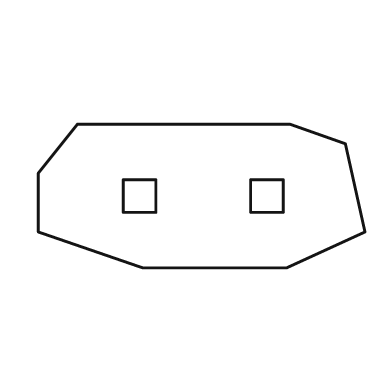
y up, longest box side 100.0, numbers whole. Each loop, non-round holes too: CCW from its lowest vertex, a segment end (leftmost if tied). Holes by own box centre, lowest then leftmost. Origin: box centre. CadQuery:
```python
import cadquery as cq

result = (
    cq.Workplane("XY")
    .moveTo(-18.0, -22.0)
    .lineTo(26.0, -22.0)
    .lineTo(50.0, -11.0)
    .lineTo(44.0, 16.0)
    .lineTo(27.0, 22.0)
    .lineTo(-38.0, 22.0)
    .lineTo(-50.0, 7.0)
    .lineTo(-50.0, -11.0)
    .close()
    .moveTo(-24.0, -5.0)
    .lineTo(-14.0, -5.0)
    .lineTo(-14.0, 5.0)
    .lineTo(-24.0, 5.0)
    .close()
    .moveTo(15.0, -5.0)
    .lineTo(25.0, -5.0)
    .lineTo(25.0, 5.0)
    .lineTo(15.0, 5.0)
    .close()
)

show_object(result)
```